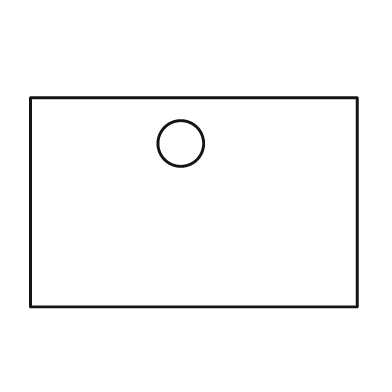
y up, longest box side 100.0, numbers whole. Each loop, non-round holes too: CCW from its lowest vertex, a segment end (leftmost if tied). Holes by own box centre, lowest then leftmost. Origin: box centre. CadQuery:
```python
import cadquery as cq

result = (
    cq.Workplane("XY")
    .moveTo(-50.0, -32.0)
    .lineTo(50.0, -32.0)
    .lineTo(50.0, 32.0)
    .lineTo(-50.0, 32.0)
    .close()
    .moveTo(-4.0, 18.0)
    .circle(7.0)
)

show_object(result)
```